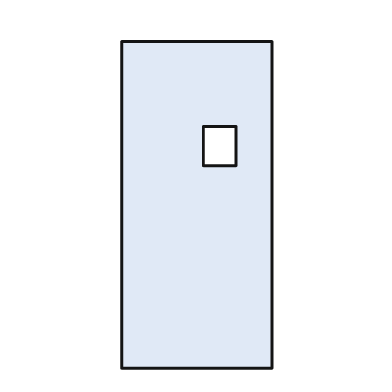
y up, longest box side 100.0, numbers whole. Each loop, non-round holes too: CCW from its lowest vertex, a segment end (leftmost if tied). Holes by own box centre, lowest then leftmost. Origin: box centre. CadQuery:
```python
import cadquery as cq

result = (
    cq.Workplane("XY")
    .moveTo(-23.0, -50.0)
    .lineTo(23.0, -50.0)
    .lineTo(23.0, 50.0)
    .lineTo(-23.0, 50.0)
    .close()
    .moveTo(2.0, 12.0)
    .lineTo(12.0, 12.0)
    .lineTo(12.0, 24.0)
    .lineTo(2.0, 24.0)
    .close()
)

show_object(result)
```